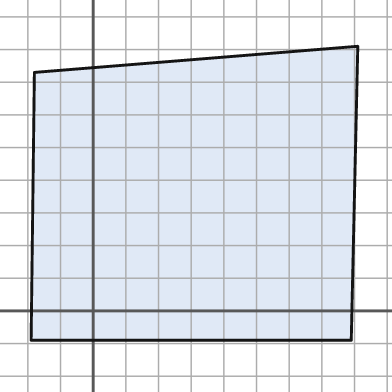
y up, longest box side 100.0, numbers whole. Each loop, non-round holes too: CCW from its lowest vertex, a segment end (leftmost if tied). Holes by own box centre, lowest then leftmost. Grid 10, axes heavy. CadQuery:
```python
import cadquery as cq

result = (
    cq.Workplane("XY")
    .moveTo(-19.0, -9.0)
    .lineTo(79.0, -9.0)
    .lineTo(81.0, 81.0)
    .lineTo(-18.0, 73.0)
    .close()
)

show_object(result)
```